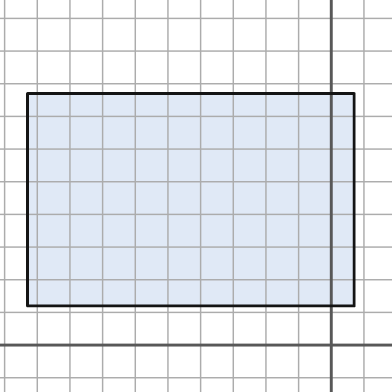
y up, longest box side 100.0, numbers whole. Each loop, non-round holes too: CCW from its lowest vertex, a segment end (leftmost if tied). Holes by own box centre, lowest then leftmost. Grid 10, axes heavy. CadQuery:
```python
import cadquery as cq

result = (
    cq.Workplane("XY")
    .moveTo(-93.0, 12.0)
    .lineTo(7.0, 12.0)
    .lineTo(7.0, 77.0)
    .lineTo(-93.0, 77.0)
    .close()
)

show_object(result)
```